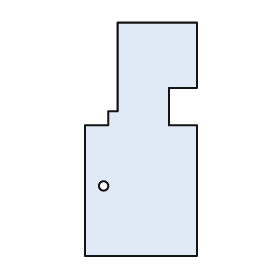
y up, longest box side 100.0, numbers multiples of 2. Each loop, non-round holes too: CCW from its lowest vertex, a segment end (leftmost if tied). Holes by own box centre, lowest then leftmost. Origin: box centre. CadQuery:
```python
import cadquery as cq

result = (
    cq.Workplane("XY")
    .moveTo(-24.0, -50.0)
    .lineTo(24.0, -50.0)
    .lineTo(24.0, 6.0)
    .lineTo(12.0, 6.0)
    .lineTo(12.0, 22.0)
    .lineTo(24.0, 22.0)
    .lineTo(24.0, 50.0)
    .lineTo(-10.0, 50.0)
    .lineTo(-10.0, 12.0)
    .lineTo(-14.0, 12.0)
    .lineTo(-14.0, 6.0)
    .lineTo(-24.0, 6.0)
    .close()
    .moveTo(-16.0, -20.0)
    .circle(2.0)
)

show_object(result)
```